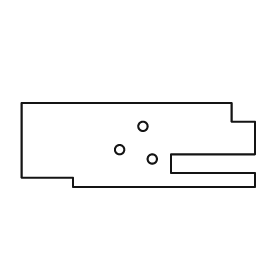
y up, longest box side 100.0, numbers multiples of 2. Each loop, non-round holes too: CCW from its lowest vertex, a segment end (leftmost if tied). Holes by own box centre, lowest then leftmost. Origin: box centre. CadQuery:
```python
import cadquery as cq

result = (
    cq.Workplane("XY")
    .moveTo(-28.0, -18.0)
    .lineTo(50.0, -18.0)
    .lineTo(50.0, -12.0)
    .lineTo(14.0, -12.0)
    .lineTo(14.0, -4.0)
    .lineTo(50.0, -4.0)
    .lineTo(50.0, 10.0)
    .lineTo(40.0, 10.0)
    .lineTo(40.0, 18.0)
    .lineTo(-50.0, 18.0)
    .lineTo(-50.0, -14.0)
    .lineTo(-28.0, -14.0)
    .close()
    .moveTo(6.0, -6.0)
    .circle(2.0)
    .moveTo(-8.0, -2.0)
    .circle(2.0)
    .moveTo(2.0, 8.0)
    .circle(2.0)
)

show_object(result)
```